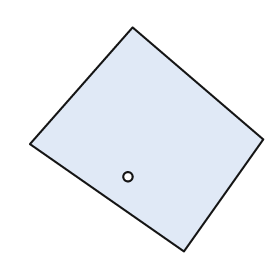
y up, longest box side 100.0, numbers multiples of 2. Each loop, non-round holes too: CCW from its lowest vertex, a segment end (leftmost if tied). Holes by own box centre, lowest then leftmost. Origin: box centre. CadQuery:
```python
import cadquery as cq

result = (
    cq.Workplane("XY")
    .moveTo(16.0, -48.0)
    .lineTo(50.0, 0.0)
    .lineTo(-6.0, 48.0)
    .lineTo(-50.0, -2.0)
    .close()
    .moveTo(-8.0, -16.0)
    .circle(2.0)
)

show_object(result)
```